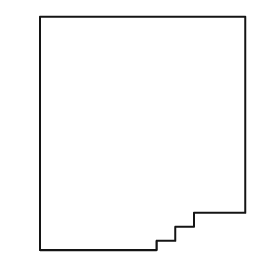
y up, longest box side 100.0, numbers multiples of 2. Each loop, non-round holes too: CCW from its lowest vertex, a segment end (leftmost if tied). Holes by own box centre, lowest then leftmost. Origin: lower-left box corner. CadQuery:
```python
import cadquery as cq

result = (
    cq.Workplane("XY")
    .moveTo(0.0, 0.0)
    .lineTo(50.0, 0.0)
    .lineTo(50.0, 4.0)
    .lineTo(58.0, 4.0)
    .lineTo(58.0, 10.0)
    .lineTo(66.0, 10.0)
    .lineTo(66.0, 16.0)
    .lineTo(88.0, 16.0)
    .lineTo(88.0, 100.0)
    .lineTo(0.0, 100.0)
    .close()
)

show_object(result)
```